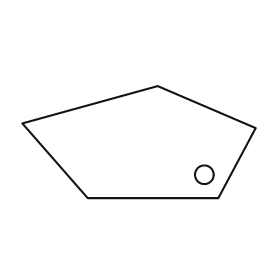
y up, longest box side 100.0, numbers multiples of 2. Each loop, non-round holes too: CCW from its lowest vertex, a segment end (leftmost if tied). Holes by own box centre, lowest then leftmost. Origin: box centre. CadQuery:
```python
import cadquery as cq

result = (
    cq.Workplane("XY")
    .moveTo(-22.0, -24.0)
    .lineTo(34.0, -24.0)
    .lineTo(50.0, 6.0)
    .lineTo(8.0, 24.0)
    .lineTo(-50.0, 8.0)
    .close()
    .moveTo(28.0, -14.0)
    .circle(4.0)
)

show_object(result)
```